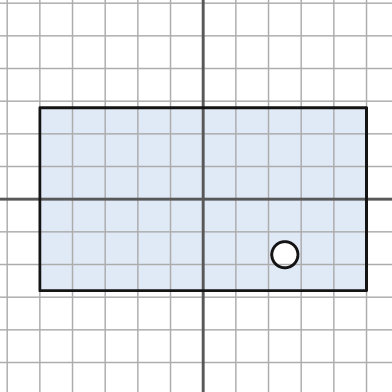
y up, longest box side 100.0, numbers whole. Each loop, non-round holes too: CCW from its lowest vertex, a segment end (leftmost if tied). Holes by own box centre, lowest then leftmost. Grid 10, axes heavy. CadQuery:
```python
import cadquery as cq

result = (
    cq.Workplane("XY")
    .moveTo(-50.0, -28.0)
    .lineTo(50.0, -28.0)
    .lineTo(50.0, 28.0)
    .lineTo(-50.0, 28.0)
    .close()
    .moveTo(25.0, -17.0)
    .circle(4.0)
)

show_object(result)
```